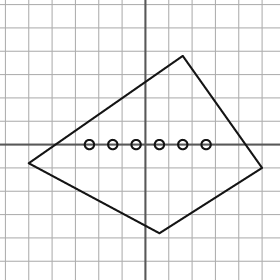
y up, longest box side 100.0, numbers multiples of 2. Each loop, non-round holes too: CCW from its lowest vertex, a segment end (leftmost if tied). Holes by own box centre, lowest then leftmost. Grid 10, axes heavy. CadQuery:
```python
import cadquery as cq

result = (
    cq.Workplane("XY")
    .moveTo(6.0, -38.0)
    .lineTo(50.0, -10.0)
    .lineTo(16.0, 38.0)
    .lineTo(-50.0, -8.0)
    .close()
    .moveTo(-24.0, 0.0)
    .circle(2.0)
    .moveTo(-14.0, 0.0)
    .circle(2.0)
    .moveTo(-4.0, 0.0)
    .circle(2.0)
    .moveTo(6.0, 0.0)
    .circle(2.0)
    .moveTo(16.0, 0.0)
    .circle(2.0)
    .moveTo(26.0, 0.0)
    .circle(2.0)
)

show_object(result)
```